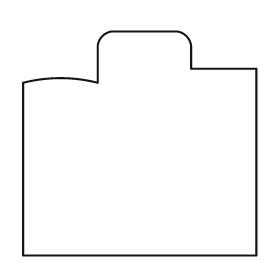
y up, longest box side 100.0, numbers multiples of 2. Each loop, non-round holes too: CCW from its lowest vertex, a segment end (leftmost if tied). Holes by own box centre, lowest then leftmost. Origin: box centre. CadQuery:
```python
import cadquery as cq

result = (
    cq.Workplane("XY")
    .moveTo(-50.0, -48.0)
    .lineTo(50.0, -48.0)
    .lineTo(50.0, 32.0)
    .lineTo(22.0, 32.0)
    .lineTo(22.0, 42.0)
    .threePointArc((20.0, 46.0), (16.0, 48.0))
    .lineTo(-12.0, 48.0)
    .threePointArc((-16.0, 46.0), (-18.0, 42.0))
    .lineTo(-18.0, 26.0)
    .threePointArc((-34.0, 28.0), (-50.0, 26.0))
    .close()
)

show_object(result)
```